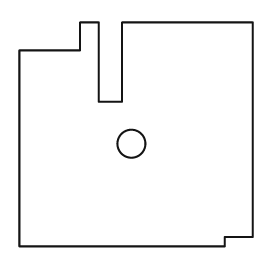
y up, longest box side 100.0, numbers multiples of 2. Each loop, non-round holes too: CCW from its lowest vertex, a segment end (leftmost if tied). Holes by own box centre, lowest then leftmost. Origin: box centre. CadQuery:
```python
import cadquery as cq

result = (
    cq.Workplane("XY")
    .moveTo(-50.0, -48.0)
    .lineTo(38.0, -48.0)
    .lineTo(38.0, -44.0)
    .lineTo(50.0, -44.0)
    .lineTo(50.0, 48.0)
    .lineTo(-6.0, 48.0)
    .lineTo(-6.0, 14.0)
    .lineTo(-16.0, 14.0)
    .lineTo(-16.0, 48.0)
    .lineTo(-24.0, 48.0)
    .lineTo(-24.0, 36.0)
    .lineTo(-50.0, 36.0)
    .close()
    .moveTo(-2.0, -4.0)
    .circle(6.0)
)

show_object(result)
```